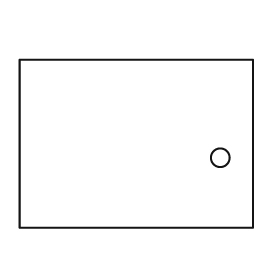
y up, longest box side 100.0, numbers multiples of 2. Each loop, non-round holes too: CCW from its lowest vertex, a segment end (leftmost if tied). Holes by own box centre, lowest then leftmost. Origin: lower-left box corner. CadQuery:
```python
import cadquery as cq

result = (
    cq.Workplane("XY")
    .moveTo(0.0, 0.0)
    .lineTo(100.0, 0.0)
    .lineTo(100.0, 72.0)
    .lineTo(0.0, 72.0)
    .close()
    .moveTo(86.0, 30.0)
    .circle(4.0)
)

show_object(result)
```